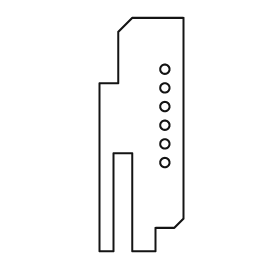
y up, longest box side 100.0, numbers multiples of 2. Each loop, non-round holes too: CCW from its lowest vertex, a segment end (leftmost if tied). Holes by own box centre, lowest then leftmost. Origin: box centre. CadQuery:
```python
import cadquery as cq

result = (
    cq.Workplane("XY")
    .moveTo(-18.0, -50.0)
    .lineTo(-12.0, -50.0)
    .lineTo(-12.0, -8.0)
    .lineTo(-4.0, -8.0)
    .lineTo(-4.0, -50.0)
    .lineTo(6.0, -50.0)
    .lineTo(6.0, -40.0)
    .lineTo(14.0, -40.0)
    .lineTo(18.0, -36.0)
    .lineTo(18.0, 50.0)
    .lineTo(-4.0, 50.0)
    .lineTo(-10.0, 44.0)
    .lineTo(-10.0, 22.0)
    .lineTo(-18.0, 22.0)
    .close()
    .moveTo(10.0, -12.0)
    .circle(2.0)
    .moveTo(10.0, -4.0)
    .circle(2.0)
    .moveTo(10.0, 4.0)
    .circle(2.0)
    .moveTo(10.0, 12.0)
    .circle(2.0)
    .moveTo(10.0, 20.0)
    .circle(2.0)
    .moveTo(10.0, 28.0)
    .circle(2.0)
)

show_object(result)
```